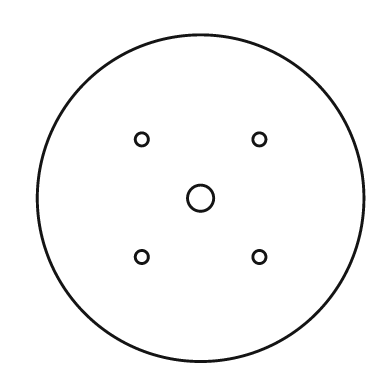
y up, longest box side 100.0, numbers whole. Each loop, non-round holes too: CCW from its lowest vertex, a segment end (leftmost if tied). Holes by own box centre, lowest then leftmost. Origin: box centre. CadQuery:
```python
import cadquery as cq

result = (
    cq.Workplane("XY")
    .moveTo(0.0, 0.0)
    .circle(50.0)
    .moveTo(-18.0, -18.0)
    .circle(2.0)
    .moveTo(18.0, -18.0)
    .circle(2.0)
    .moveTo(0.0, 0.0)
    .circle(4.0)
    .moveTo(-18.0, 18.0)
    .circle(2.0)
    .moveTo(18.0, 18.0)
    .circle(2.0)
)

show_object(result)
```